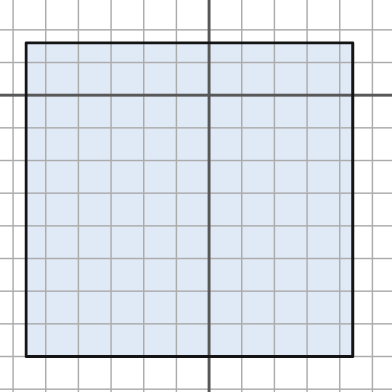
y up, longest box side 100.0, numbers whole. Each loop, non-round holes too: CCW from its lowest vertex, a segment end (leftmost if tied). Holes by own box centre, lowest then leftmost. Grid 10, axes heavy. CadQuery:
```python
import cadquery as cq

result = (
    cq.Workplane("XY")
    .moveTo(-56.0, -80.0)
    .lineTo(44.0, -80.0)
    .lineTo(44.0, 16.0)
    .lineTo(-56.0, 16.0)
    .close()
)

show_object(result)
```